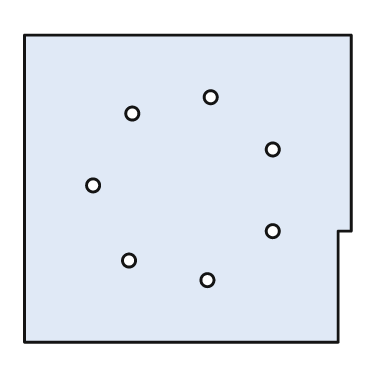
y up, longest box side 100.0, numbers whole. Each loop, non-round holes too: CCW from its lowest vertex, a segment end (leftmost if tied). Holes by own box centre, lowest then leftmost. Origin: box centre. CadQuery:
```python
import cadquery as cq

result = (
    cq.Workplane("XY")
    .moveTo(-50.0, -47.0)
    .lineTo(46.0, -47.0)
    .lineTo(46.0, -13.0)
    .lineTo(50.0, -13.0)
    .lineTo(50.0, 47.0)
    .lineTo(-50.0, 47.0)
    .close()
    .moveTo(6.0, -28.0)
    .circle(2.0)
    .moveTo(-18.0, -22.0)
    .circle(2.0)
    .moveTo(26.0, -13.0)
    .circle(2.0)
    .moveTo(-29.0, 1.0)
    .circle(2.0)
    .moveTo(26.0, 12.0)
    .circle(2.0)
    .moveTo(-17.0, 23.0)
    .circle(2.0)
    .moveTo(7.0, 28.0)
    .circle(2.0)
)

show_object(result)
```